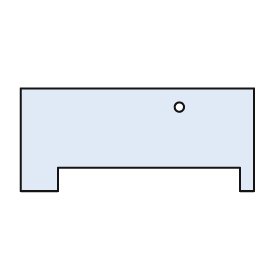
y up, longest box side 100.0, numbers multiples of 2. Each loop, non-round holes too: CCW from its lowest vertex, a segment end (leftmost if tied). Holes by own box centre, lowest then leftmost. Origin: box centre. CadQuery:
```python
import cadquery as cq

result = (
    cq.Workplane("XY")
    .moveTo(-50.0, -22.0)
    .lineTo(-34.0, -22.0)
    .lineTo(-34.0, -12.0)
    .lineTo(44.0, -12.0)
    .lineTo(44.0, -22.0)
    .lineTo(50.0, -22.0)
    .lineTo(50.0, 22.0)
    .lineTo(-50.0, 22.0)
    .close()
    .moveTo(18.0, 14.0)
    .circle(2.0)
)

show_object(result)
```